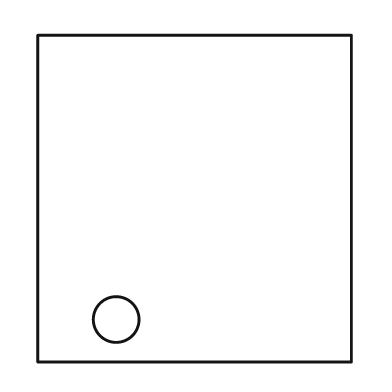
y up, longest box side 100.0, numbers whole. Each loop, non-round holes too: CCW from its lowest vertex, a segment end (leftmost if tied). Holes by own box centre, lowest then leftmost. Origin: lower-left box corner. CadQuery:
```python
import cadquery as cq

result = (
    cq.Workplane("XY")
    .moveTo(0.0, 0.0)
    .lineTo(96.0, 0.0)
    .lineTo(96.0, 100.0)
    .lineTo(0.0, 100.0)
    .close()
    .moveTo(24.0, 13.0)
    .circle(7.0)
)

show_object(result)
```